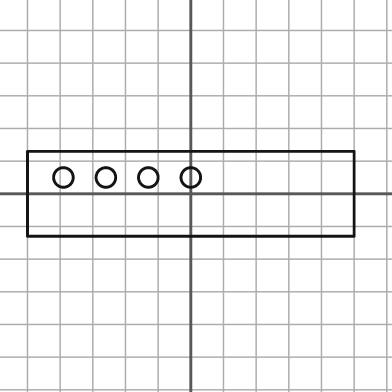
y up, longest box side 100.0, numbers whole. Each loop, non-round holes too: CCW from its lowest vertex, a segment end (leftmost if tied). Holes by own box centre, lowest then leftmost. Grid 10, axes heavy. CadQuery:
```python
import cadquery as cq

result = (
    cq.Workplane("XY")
    .moveTo(-50.0, -13.0)
    .lineTo(50.0, -13.0)
    .lineTo(50.0, 13.0)
    .lineTo(-50.0, 13.0)
    .close()
    .moveTo(-39.0, 5.0)
    .circle(3.0)
    .moveTo(-26.0, 5.0)
    .circle(3.0)
    .moveTo(-13.0, 5.0)
    .circle(3.0)
    .moveTo(0.0, 5.0)
    .circle(3.0)
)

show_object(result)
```